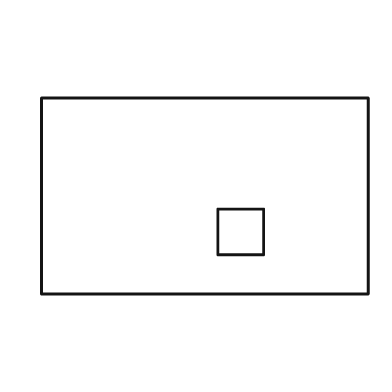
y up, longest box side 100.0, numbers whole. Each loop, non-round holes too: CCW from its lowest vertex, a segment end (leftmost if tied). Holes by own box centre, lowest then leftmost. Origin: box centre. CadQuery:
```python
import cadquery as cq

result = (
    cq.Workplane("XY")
    .moveTo(-50.0, -30.0)
    .lineTo(50.0, -30.0)
    .lineTo(50.0, 30.0)
    .lineTo(-50.0, 30.0)
    .close()
    .moveTo(4.0, -18.0)
    .lineTo(18.0, -18.0)
    .lineTo(18.0, -4.0)
    .lineTo(4.0, -4.0)
    .close()
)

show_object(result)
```